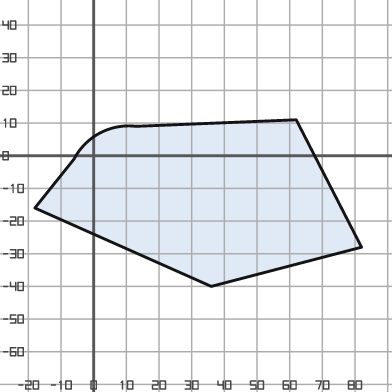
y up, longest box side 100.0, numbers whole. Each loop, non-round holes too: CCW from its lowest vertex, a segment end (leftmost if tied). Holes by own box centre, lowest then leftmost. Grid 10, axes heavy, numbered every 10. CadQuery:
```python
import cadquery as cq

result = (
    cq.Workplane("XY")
    .moveTo(36.0, -40.0)
    .lineTo(82.0, -28.0)
    .lineTo(62.0, 11.0)
    .lineTo(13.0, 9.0)
    .threePointArc((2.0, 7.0), (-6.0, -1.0))
    .lineTo(-18.0, -16.0)
    .close()
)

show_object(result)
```